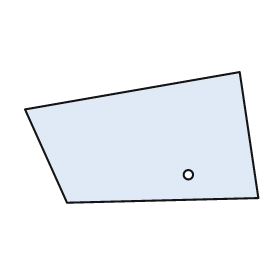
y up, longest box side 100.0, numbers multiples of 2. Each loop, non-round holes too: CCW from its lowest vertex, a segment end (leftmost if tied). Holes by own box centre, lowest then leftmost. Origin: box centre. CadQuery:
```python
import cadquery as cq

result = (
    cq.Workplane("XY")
    .moveTo(-32.0, -28.0)
    .lineTo(50.0, -26.0)
    .lineTo(42.0, 28.0)
    .lineTo(-50.0, 12.0)
    .close()
    .moveTo(20.0, -16.0)
    .circle(2.0)
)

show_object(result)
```